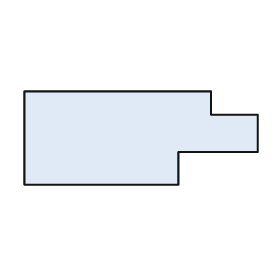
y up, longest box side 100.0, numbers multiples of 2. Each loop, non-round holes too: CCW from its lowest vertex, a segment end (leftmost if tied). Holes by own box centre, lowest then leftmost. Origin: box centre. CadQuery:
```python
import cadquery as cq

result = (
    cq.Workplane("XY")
    .moveTo(-50.0, -20.0)
    .lineTo(16.0, -20.0)
    .lineTo(16.0, -6.0)
    .lineTo(50.0, -6.0)
    .lineTo(50.0, 10.0)
    .lineTo(30.0, 10.0)
    .lineTo(30.0, 20.0)
    .lineTo(-50.0, 20.0)
    .close()
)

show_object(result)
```